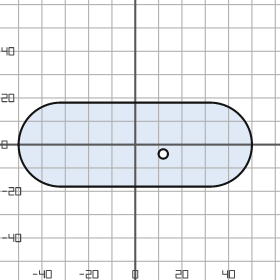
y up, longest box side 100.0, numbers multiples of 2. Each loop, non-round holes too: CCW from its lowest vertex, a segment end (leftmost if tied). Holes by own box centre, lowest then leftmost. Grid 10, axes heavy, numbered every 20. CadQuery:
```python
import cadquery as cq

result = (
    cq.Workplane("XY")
    .moveTo(-32.0, -18.0)
    .lineTo(32.0, -18.0)
    .threePointArc((50.0, 0.0), (32.0, 18.0))
    .lineTo(-32.0, 18.0)
    .threePointArc((-50.0, 0.0), (-32.0, -18.0))
    .close()
    .moveTo(12.0, -4.0)
    .circle(2.0)
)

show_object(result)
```